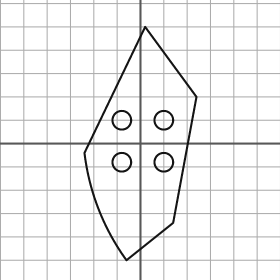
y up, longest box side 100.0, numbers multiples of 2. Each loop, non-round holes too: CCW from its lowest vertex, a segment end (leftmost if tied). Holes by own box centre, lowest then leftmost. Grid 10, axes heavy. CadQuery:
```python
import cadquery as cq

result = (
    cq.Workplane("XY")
    .moveTo(-6.0, -50.0)
    .lineTo(14.0, -34.0)
    .lineTo(24.0, 20.0)
    .lineTo(2.0, 50.0)
    .lineTo(-24.0, -4.0)
    .threePointArc((-18.0, -28.0), (-6.0, -50.0))
    .close()
    .moveTo(-8.0, -8.0)
    .circle(4.0)
    .moveTo(10.0, -8.0)
    .circle(4.0)
    .moveTo(-8.0, 10.0)
    .circle(4.0)
    .moveTo(10.0, 10.0)
    .circle(4.0)
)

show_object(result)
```